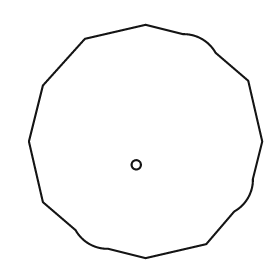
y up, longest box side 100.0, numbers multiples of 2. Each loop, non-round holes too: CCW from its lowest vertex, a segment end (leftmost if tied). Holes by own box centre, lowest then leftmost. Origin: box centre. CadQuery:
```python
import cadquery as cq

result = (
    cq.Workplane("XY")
    .moveTo(0.0, -50.0)
    .lineTo(26.0, -44.0)
    .lineTo(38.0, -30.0)
    .threePointArc((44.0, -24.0), (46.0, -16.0))
    .lineTo(50.0, 0.0)
    .lineTo(44.0, 26.0)
    .lineTo(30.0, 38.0)
    .threePointArc((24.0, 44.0), (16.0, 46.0))
    .lineTo(0.0, 50.0)
    .lineTo(-26.0, 44.0)
    .lineTo(-44.0, 24.0)
    .lineTo(-50.0, 0.0)
    .lineTo(-44.0, -26.0)
    .lineTo(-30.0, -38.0)
    .threePointArc((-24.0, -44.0), (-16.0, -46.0))
    .close()
    .moveTo(-4.0, -10.0)
    .circle(2.0)
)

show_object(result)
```